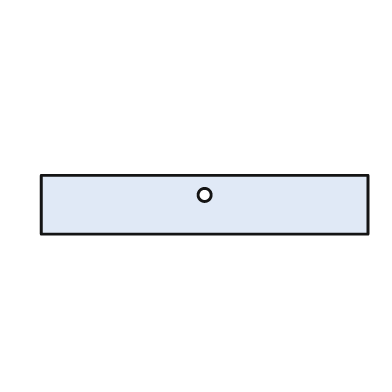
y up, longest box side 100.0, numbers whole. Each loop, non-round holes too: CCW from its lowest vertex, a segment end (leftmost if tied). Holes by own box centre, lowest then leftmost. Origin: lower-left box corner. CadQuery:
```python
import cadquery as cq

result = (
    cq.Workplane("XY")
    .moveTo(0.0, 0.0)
    .lineTo(100.0, 0.0)
    .lineTo(100.0, 18.0)
    .lineTo(0.0, 18.0)
    .close()
    .moveTo(50.0, 12.0)
    .circle(2.0)
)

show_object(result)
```